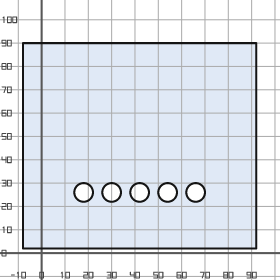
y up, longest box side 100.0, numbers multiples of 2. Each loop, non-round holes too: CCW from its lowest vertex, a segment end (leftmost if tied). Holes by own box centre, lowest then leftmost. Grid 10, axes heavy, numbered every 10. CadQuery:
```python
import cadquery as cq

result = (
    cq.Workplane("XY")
    .moveTo(-8.0, 2.0)
    .lineTo(92.0, 2.0)
    .lineTo(92.0, 90.0)
    .lineTo(-8.0, 90.0)
    .close()
    .moveTo(18.0, 26.0)
    .circle(4.0)
    .moveTo(30.0, 26.0)
    .circle(4.0)
    .moveTo(42.0, 26.0)
    .circle(4.0)
    .moveTo(54.0, 26.0)
    .circle(4.0)
    .moveTo(66.0, 26.0)
    .circle(4.0)
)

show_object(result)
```